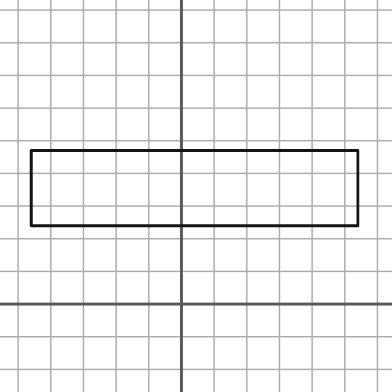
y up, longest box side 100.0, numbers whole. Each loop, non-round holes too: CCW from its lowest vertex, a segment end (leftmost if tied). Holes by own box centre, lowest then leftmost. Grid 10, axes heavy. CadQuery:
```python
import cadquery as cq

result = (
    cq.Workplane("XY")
    .moveTo(-46.0, 24.0)
    .lineTo(54.0, 24.0)
    .lineTo(54.0, 47.0)
    .lineTo(-46.0, 47.0)
    .close()
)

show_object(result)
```